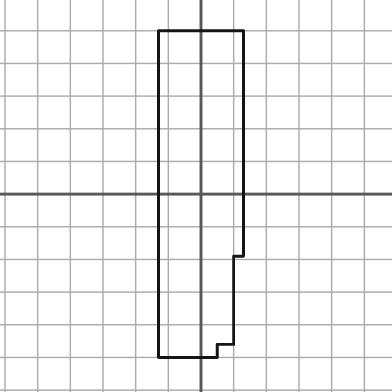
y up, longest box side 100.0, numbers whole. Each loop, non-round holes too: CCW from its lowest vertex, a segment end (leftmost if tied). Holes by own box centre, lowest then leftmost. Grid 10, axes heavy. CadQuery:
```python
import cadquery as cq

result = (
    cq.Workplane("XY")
    .moveTo(-13.0, -50.0)
    .lineTo(5.0, -50.0)
    .lineTo(5.0, -46.0)
    .lineTo(10.0, -46.0)
    .lineTo(10.0, -19.0)
    .lineTo(13.0, -19.0)
    .lineTo(13.0, 50.0)
    .lineTo(-13.0, 50.0)
    .close()
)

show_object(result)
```